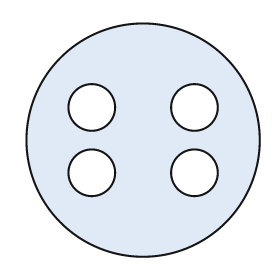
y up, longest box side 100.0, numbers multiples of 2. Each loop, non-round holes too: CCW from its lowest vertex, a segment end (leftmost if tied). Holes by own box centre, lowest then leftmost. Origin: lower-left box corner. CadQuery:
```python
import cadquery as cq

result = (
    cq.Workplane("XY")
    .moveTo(50.0, 50.0)
    .circle(50.0)
    .moveTo(28.0, 36.0)
    .circle(10.0)
    .moveTo(72.0, 36.0)
    .circle(10.0)
    .moveTo(28.0, 64.0)
    .circle(10.0)
    .moveTo(72.0, 64.0)
    .circle(10.0)
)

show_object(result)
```